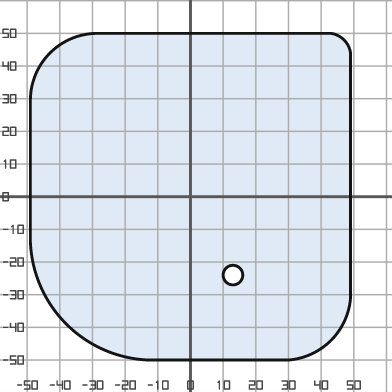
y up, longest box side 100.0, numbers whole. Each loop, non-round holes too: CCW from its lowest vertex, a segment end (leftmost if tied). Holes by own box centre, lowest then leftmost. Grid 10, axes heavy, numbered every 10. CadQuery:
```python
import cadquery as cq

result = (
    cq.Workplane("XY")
    .moveTo(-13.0, -50.0)
    .lineTo(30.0, -50.0)
    .threePointArc((43.0, -44.0), (49.0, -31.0))
    .lineTo(49.0, 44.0)
    .threePointArc((47.0, 48.0), (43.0, 50.0))
    .lineTo(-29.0, 50.0)
    .threePointArc((-43.0, 44.0), (-49.0, 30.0))
    .lineTo(-49.0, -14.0)
    .threePointArc((-38.0, -39.0), (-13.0, -50.0))
    .close()
    .moveTo(13.0, -24.0)
    .circle(3.0)
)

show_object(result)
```